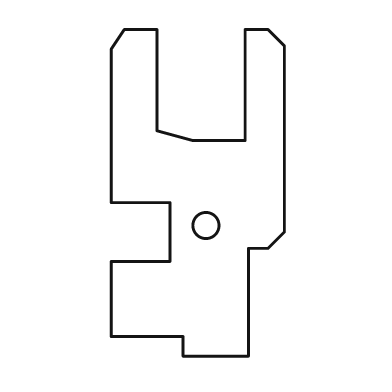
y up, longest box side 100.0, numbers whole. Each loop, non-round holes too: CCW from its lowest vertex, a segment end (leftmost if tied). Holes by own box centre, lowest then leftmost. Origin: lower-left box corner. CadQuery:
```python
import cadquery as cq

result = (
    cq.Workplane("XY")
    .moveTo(22.0, 0.0)
    .lineTo(42.0, 0.0)
    .lineTo(42.0, 33.0)
    .lineTo(48.0, 33.0)
    .lineTo(53.0, 38.0)
    .lineTo(53.0, 95.0)
    .lineTo(48.0, 100.0)
    .lineTo(41.0, 100.0)
    .lineTo(41.0, 66.0)
    .lineTo(25.0, 66.0)
    .lineTo(14.0, 69.0)
    .lineTo(14.0, 100.0)
    .lineTo(4.0, 100.0)
    .lineTo(0.0, 94.0)
    .lineTo(0.0, 47.0)
    .lineTo(18.0, 47.0)
    .lineTo(18.0, 29.0)
    .lineTo(0.0, 29.0)
    .lineTo(0.0, 6.0)
    .lineTo(22.0, 6.0)
    .close()
    .moveTo(29.0, 40.0)
    .circle(4.0)
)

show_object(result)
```